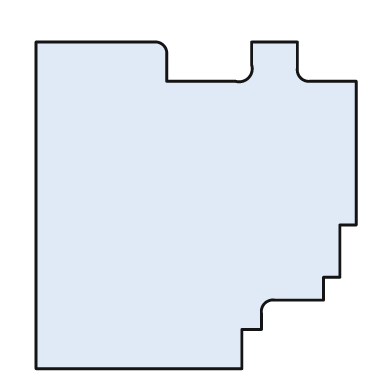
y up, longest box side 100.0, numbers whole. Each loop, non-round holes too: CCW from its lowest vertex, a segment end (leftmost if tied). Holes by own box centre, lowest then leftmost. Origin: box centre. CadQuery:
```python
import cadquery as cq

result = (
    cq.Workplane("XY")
    .moveTo(-49.0, -50.0)
    .lineTo(14.0, -50.0)
    .lineTo(14.0, -38.0)
    .lineTo(20.0, -38.0)
    .lineTo(20.0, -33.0)
    .threePointArc((21.0, -30.0), (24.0, -29.0))
    .lineTo(39.0, -29.0)
    .lineTo(39.0, -22.0)
    .lineTo(44.0, -22.0)
    .lineTo(44.0, -6.0)
    .lineTo(49.0, -6.0)
    .lineTo(49.0, 38.0)
    .lineTo(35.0, 38.0)
    .threePointArc((32.0, 39.0), (31.0, 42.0))
    .lineTo(31.0, 50.0)
    .lineTo(17.0, 50.0)
    .lineTo(17.0, 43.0)
    .threePointArc((16.0, 39.0), (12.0, 38.0))
    .lineTo(-9.0, 38.0)
    .lineTo(-9.0, 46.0)
    .threePointArc((-10.0, 49.0), (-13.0, 50.0))
    .lineTo(-49.0, 50.0)
    .close()
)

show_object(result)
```